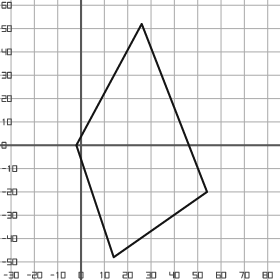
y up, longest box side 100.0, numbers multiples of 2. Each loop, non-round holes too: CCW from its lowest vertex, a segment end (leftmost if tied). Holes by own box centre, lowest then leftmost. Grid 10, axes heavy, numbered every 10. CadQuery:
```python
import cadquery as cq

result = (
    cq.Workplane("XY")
    .moveTo(14.0, -48.0)
    .lineTo(54.0, -20.0)
    .lineTo(26.0, 52.0)
    .lineTo(-2.0, 0.0)
    .close()
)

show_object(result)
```